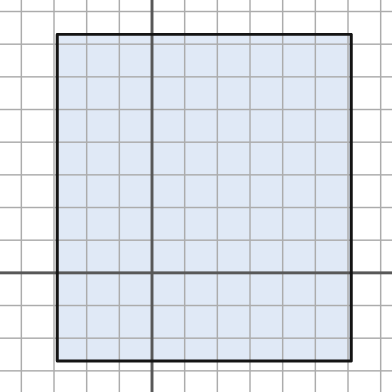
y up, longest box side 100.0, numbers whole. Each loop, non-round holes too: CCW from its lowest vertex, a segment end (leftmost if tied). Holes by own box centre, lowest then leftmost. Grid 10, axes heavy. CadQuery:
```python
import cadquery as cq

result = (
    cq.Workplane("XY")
    .moveTo(-29.0, -27.0)
    .lineTo(61.0, -27.0)
    .lineTo(61.0, 73.0)
    .lineTo(-29.0, 73.0)
    .close()
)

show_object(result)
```